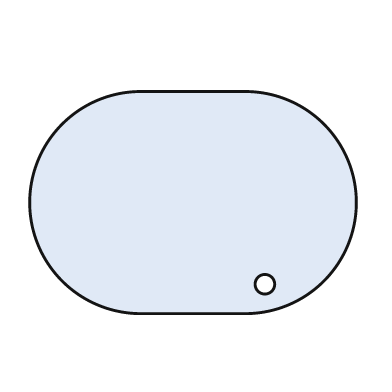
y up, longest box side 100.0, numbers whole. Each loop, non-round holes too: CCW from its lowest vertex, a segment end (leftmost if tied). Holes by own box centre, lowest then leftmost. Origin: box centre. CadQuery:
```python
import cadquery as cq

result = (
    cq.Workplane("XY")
    .moveTo(-16.0, -34.0)
    .lineTo(16.0, -34.0)
    .threePointArc((50.0, 0.0), (16.0, 34.0))
    .lineTo(-16.0, 34.0)
    .threePointArc((-50.0, 0.0), (-16.0, -34.0))
    .close()
    .moveTo(22.0, -25.0)
    .circle(3.0)
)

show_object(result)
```